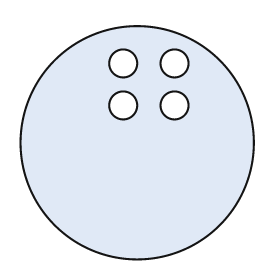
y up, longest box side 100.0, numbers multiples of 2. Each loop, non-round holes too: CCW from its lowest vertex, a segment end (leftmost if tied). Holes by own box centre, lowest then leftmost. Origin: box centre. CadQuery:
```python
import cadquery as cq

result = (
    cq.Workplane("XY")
    .moveTo(0.0, 0.0)
    .circle(50.0)
    .moveTo(-6.0, 16.0)
    .circle(6.0)
    .moveTo(16.0, 16.0)
    .circle(6.0)
    .moveTo(-6.0, 34.0)
    .circle(6.0)
    .moveTo(16.0, 34.0)
    .circle(6.0)
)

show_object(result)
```